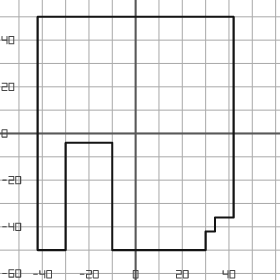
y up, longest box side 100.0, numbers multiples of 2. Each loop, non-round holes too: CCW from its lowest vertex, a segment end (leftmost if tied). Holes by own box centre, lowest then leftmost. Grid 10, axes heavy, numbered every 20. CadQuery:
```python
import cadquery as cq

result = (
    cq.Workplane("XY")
    .moveTo(-42.0, -50.0)
    .lineTo(-30.0, -50.0)
    .lineTo(-30.0, -4.0)
    .lineTo(-10.0, -4.0)
    .lineTo(-10.0, -50.0)
    .lineTo(30.0, -50.0)
    .lineTo(30.0, -42.0)
    .lineTo(34.0, -42.0)
    .lineTo(34.0, -36.0)
    .lineTo(42.0, -36.0)
    .lineTo(42.0, 50.0)
    .lineTo(-42.0, 50.0)
    .close()
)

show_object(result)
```